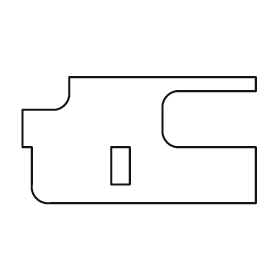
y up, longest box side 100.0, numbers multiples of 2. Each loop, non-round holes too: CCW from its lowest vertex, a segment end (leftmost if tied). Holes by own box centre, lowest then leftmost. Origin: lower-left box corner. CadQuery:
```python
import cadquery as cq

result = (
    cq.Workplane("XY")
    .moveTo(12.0, 0.0)
    .lineTo(100.0, 0.0)
    .lineTo(100.0, 24.0)
    .lineTo(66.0, 24.0)
    .threePointArc((62.0, 26.0), (60.0, 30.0))
    .lineTo(60.0, 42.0)
    .threePointArc((62.0, 46.0), (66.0, 48.0))
    .lineTo(100.0, 48.0)
    .lineTo(100.0, 54.0)
    .lineTo(20.0, 54.0)
    .lineTo(20.0, 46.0)
    .threePointArc((18.0, 42.0), (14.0, 40.0))
    .lineTo(0.0, 40.0)
    .lineTo(0.0, 24.0)
    .lineTo(4.0, 24.0)
    .lineTo(4.0, 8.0)
    .threePointArc((6.0, 2.0), (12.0, 0.0))
    .close()
    .moveTo(38.0, 8.0)
    .lineTo(46.0, 8.0)
    .lineTo(46.0, 24.0)
    .lineTo(38.0, 24.0)
    .close()
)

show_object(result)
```